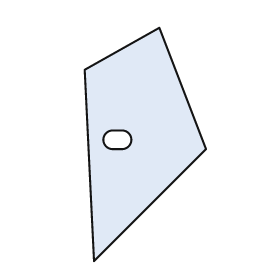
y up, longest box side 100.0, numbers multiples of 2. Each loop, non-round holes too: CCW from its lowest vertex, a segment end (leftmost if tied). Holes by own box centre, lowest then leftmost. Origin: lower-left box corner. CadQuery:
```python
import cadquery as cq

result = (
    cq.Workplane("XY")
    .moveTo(4.0, 0.0)
    .lineTo(52.0, 48.0)
    .lineTo(32.0, 100.0)
    .lineTo(0.0, 82.0)
    .close()
    .moveTo(12.0, 48.0)
    .lineTo(16.0, 48.0)
    .threePointArc((20.0, 52.0), (16.0, 56.0))
    .lineTo(12.0, 56.0)
    .threePointArc((8.0, 52.0), (12.0, 48.0))
    .close()
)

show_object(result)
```